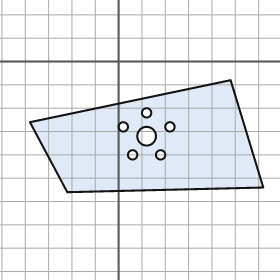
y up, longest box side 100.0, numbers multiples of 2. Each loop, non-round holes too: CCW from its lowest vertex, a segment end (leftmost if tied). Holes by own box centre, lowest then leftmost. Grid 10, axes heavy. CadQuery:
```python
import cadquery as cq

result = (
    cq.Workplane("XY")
    .moveTo(-22.0, -56.0)
    .lineTo(62.0, -54.0)
    .lineTo(48.0, -8.0)
    .lineTo(-38.0, -26.0)
    .close()
    .moveTo(6.0, -40.0)
    .circle(2.0)
    .moveTo(18.0, -40.0)
    .circle(2.0)
    .moveTo(12.0, -32.0)
    .circle(4.0)
    .moveTo(2.0, -28.0)
    .circle(2.0)
    .moveTo(22.0, -28.0)
    .circle(2.0)
    .moveTo(12.0, -22.0)
    .circle(2.0)
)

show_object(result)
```